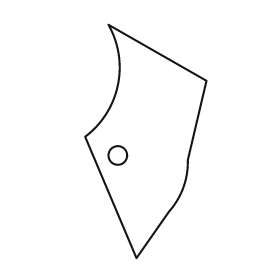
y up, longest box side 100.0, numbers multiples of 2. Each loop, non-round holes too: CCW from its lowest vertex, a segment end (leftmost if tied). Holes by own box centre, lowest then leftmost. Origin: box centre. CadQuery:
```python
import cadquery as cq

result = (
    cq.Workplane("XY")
    .moveTo(-4.0, -50.0)
    .lineTo(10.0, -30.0)
    .threePointArc((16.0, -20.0), (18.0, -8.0))
    .lineTo(26.0, 26.0)
    .lineTo(-16.0, 50.0)
    .threePointArc((-12.0, 24.0), (-26.0, 2.0))
    .close()
    .moveTo(-12.0, -6.0)
    .circle(4.0)
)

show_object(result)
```